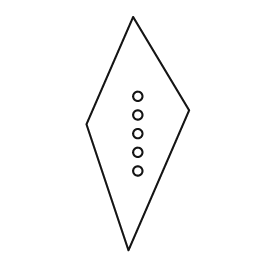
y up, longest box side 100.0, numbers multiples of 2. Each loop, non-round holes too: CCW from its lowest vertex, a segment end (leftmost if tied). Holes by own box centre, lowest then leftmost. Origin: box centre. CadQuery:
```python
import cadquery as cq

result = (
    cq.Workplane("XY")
    .moveTo(-4.0, -50.0)
    .lineTo(22.0, 10.0)
    .lineTo(-2.0, 50.0)
    .lineTo(-22.0, 4.0)
    .close()
    .moveTo(0.0, -16.0)
    .circle(2.0)
    .moveTo(0.0, -8.0)
    .circle(2.0)
    .moveTo(0.0, 0.0)
    .circle(2.0)
    .moveTo(0.0, 8.0)
    .circle(2.0)
    .moveTo(0.0, 16.0)
    .circle(2.0)
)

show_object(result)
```